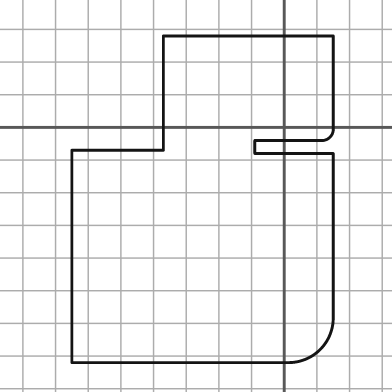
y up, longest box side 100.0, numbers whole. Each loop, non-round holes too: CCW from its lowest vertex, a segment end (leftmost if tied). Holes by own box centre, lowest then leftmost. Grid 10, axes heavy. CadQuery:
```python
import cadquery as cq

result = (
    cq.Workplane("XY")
    .moveTo(-65.0, -72.0)
    .lineTo(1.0, -72.0)
    .threePointArc((11.0, -68.0), (15.0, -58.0))
    .lineTo(15.0, -8.0)
    .lineTo(-9.0, -8.0)
    .lineTo(-9.0, -4.0)
    .lineTo(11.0, -4.0)
    .threePointArc((14.0, -3.0), (15.0, 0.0))
    .lineTo(15.0, 28.0)
    .lineTo(-37.0, 28.0)
    .lineTo(-37.0, -7.0)
    .lineTo(-65.0, -7.0)
    .close()
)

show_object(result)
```